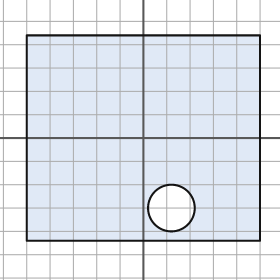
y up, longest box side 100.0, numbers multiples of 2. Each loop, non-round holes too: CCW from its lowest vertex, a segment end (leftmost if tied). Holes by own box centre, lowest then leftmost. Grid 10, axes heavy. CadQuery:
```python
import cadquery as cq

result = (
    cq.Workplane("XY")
    .moveTo(-50.0, -44.0)
    .lineTo(50.0, -44.0)
    .lineTo(50.0, 44.0)
    .lineTo(-50.0, 44.0)
    .close()
    .moveTo(12.0, -30.0)
    .circle(10.0)
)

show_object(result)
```